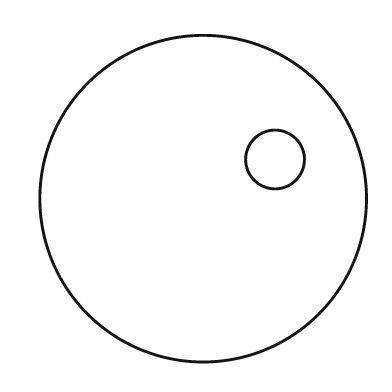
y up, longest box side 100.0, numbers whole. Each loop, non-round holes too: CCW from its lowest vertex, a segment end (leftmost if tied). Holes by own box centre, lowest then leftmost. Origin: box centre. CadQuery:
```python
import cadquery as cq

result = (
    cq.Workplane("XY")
    .moveTo(0.0, 0.0)
    .circle(50.0)
    .moveTo(22.0, 12.0)
    .circle(9.0)
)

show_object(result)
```